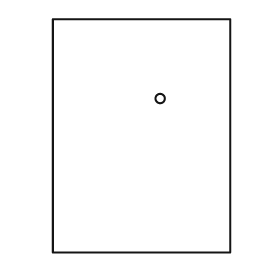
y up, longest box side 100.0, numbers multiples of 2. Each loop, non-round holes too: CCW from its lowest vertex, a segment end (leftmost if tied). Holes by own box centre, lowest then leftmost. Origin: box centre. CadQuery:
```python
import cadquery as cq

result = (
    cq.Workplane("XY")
    .moveTo(-38.0, -50.0)
    .lineTo(38.0, -50.0)
    .lineTo(38.0, 50.0)
    .lineTo(-38.0, 50.0)
    .close()
    .moveTo(8.0, 16.0)
    .circle(2.0)
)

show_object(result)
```